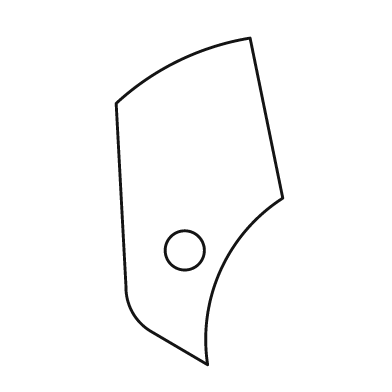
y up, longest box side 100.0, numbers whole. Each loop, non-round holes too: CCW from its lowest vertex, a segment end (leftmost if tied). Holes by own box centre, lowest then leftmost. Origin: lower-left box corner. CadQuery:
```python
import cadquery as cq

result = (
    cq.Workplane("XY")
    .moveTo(28.0, 0.0)
    .threePointArc((32.0, 29.0), (51.0, 51.0))
    .lineTo(41.0, 100.0)
    .threePointArc((19.0, 93.0), (0.0, 80.0))
    .lineTo(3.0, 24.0)
    .threePointArc((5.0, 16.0), (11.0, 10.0))
    .close()
    .moveTo(21.0, 35.0)
    .circle(6.0)
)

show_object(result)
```